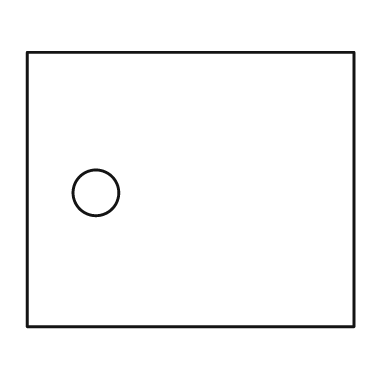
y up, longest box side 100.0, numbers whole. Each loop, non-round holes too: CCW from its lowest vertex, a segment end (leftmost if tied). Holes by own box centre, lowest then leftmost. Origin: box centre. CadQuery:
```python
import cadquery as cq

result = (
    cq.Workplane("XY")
    .moveTo(-50.0, -42.0)
    .lineTo(50.0, -42.0)
    .lineTo(50.0, 42.0)
    .lineTo(-50.0, 42.0)
    .close()
    .moveTo(-29.0, -1.0)
    .circle(7.0)
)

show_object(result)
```